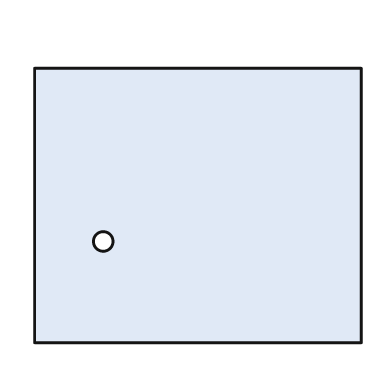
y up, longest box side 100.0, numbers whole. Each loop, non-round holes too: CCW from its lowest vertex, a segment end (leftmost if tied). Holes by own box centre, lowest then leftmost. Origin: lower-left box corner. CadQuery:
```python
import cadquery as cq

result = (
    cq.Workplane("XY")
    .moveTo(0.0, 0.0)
    .lineTo(100.0, 0.0)
    .lineTo(100.0, 84.0)
    .lineTo(0.0, 84.0)
    .close()
    .moveTo(21.0, 31.0)
    .circle(3.0)
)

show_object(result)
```